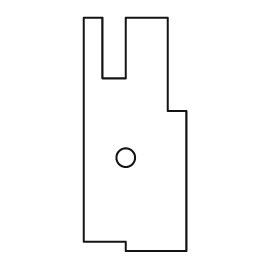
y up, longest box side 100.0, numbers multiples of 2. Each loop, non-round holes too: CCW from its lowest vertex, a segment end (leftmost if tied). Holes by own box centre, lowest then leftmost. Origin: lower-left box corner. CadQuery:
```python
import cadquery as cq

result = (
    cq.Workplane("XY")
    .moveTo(18.0, 0.0)
    .lineTo(44.0, 0.0)
    .lineTo(44.0, 60.0)
    .lineTo(36.0, 60.0)
    .lineTo(36.0, 100.0)
    .lineTo(18.0, 100.0)
    .lineTo(18.0, 74.0)
    .lineTo(8.0, 74.0)
    .lineTo(8.0, 100.0)
    .lineTo(0.0, 100.0)
    .lineTo(0.0, 4.0)
    .lineTo(18.0, 4.0)
    .close()
    .moveTo(18.0, 40.0)
    .circle(4.0)
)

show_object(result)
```